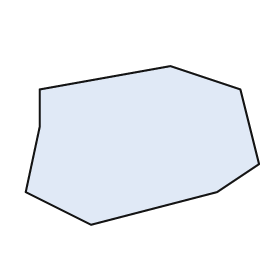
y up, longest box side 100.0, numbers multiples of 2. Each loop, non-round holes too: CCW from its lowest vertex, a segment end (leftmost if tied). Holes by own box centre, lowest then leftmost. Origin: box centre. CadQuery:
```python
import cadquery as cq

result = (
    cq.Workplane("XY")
    .moveTo(-22.0, -34.0)
    .lineTo(32.0, -20.0)
    .lineTo(50.0, -8.0)
    .lineTo(42.0, 24.0)
    .lineTo(12.0, 34.0)
    .lineTo(-44.0, 24.0)
    .lineTo(-44.0, 8.0)
    .lineTo(-50.0, -20.0)
    .close()
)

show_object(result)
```